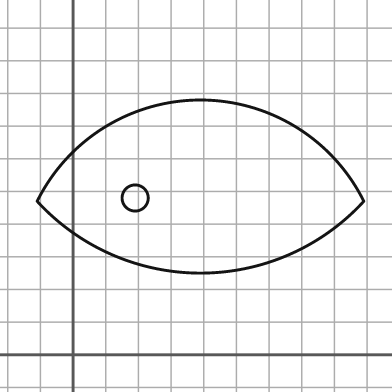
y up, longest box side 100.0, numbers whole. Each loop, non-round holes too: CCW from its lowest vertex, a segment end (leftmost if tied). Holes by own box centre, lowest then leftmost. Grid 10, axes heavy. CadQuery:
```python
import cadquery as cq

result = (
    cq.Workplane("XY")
    .moveTo(-11.0, 47.0)
    .threePointArc((39.0, 25.0), (89.0, 47.0))
    .threePointArc((39.0, 78.0), (-11.0, 47.0))
    .close()
    .moveTo(19.0, 48.0)
    .circle(4.0)
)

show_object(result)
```